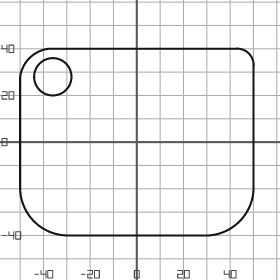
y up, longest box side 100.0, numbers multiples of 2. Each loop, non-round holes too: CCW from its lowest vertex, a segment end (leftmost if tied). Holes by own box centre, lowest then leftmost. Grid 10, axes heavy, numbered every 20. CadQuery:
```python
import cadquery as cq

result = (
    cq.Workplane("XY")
    .moveTo(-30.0, -40.0)
    .lineTo(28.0, -40.0)
    .threePointArc((44.0, -34.0), (50.0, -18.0))
    .lineTo(50.0, 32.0)
    .threePointArc((48.0, 38.0), (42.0, 40.0))
    .lineTo(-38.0, 40.0)
    .threePointArc((-46.0, 36.0), (-50.0, 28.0))
    .lineTo(-50.0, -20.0)
    .threePointArc((-44.0, -34.0), (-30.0, -40.0))
    .close()
    .moveTo(-36.0, 28.0)
    .circle(8.0)
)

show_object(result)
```